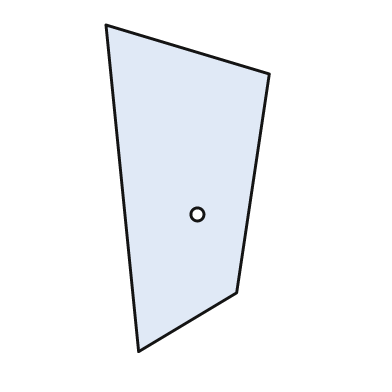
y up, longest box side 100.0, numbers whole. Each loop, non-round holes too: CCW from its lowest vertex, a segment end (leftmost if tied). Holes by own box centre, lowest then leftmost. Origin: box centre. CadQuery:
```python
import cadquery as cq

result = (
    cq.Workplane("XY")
    .moveTo(-15.0, -50.0)
    .lineTo(15.0, -32.0)
    .lineTo(25.0, 35.0)
    .lineTo(-25.0, 50.0)
    .close()
    .moveTo(3.0, -8.0)
    .circle(2.0)
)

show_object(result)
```